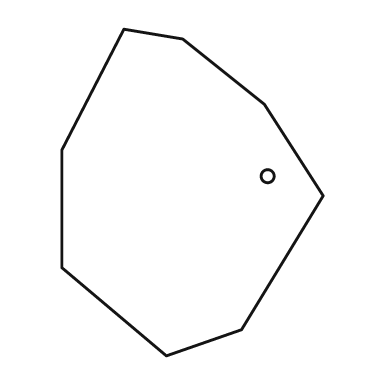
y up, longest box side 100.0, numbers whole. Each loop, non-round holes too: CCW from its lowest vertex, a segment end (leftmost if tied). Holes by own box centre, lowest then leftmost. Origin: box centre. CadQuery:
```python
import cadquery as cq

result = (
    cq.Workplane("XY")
    .moveTo(-8.0, -50.0)
    .lineTo(15.0, -42.0)
    .lineTo(40.0, -1.0)
    .lineTo(22.0, 27.0)
    .lineTo(-3.0, 47.0)
    .lineTo(-21.0, 50.0)
    .lineTo(-40.0, 13.0)
    .lineTo(-40.0, -23.0)
    .close()
    .moveTo(23.0, 5.0)
    .circle(2.0)
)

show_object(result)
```